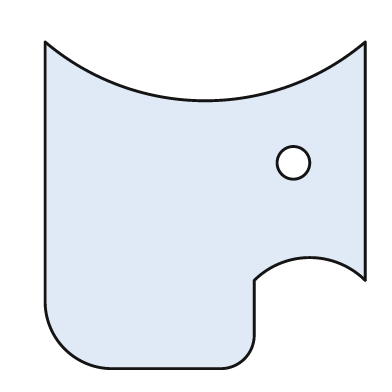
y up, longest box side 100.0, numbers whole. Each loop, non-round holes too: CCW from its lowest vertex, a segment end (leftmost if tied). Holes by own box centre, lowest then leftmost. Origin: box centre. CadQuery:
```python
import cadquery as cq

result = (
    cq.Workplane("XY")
    .moveTo(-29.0, -50.0)
    .lineTo(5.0, -50.0)
    .threePointArc((12.0, -47.0), (15.0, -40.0))
    .lineTo(15.0, -23.0)
    .threePointArc((32.0, -16.0), (49.0, -23.0))
    .lineTo(49.0, 50.0)
    .threePointArc((0.0, 32.0), (-49.0, 50.0))
    .lineTo(-49.0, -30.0)
    .threePointArc((-43.0, -44.0), (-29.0, -50.0))
    .close()
    .moveTo(27.0, 13.0)
    .circle(5.0)
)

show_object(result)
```